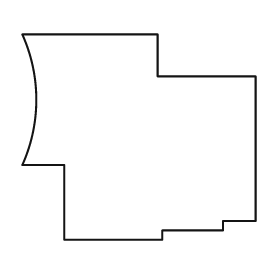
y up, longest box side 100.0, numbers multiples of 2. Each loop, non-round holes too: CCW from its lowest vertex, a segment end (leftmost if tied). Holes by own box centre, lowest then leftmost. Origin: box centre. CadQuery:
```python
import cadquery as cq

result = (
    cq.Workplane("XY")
    .moveTo(-32.0, -44.0)
    .lineTo(10.0, -44.0)
    .lineTo(10.0, -40.0)
    .lineTo(36.0, -40.0)
    .lineTo(36.0, -36.0)
    .lineTo(50.0, -36.0)
    .lineTo(50.0, 26.0)
    .lineTo(8.0, 26.0)
    .lineTo(8.0, 44.0)
    .lineTo(-50.0, 44.0)
    .threePointArc((-44.0, 16.0), (-50.0, -12.0))
    .lineTo(-32.0, -12.0)
    .close()
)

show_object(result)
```